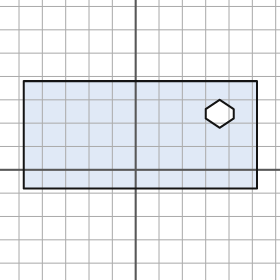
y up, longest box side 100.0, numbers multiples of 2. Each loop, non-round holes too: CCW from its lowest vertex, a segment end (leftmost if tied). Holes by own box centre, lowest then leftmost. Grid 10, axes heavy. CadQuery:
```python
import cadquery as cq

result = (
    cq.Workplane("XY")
    .moveTo(-48.0, -8.0)
    .lineTo(52.0, -8.0)
    .lineTo(52.0, 38.0)
    .lineTo(-48.0, 38.0)
    .close()
    .moveTo(36.0, 18.0)
    .lineTo(42.0, 22.0)
    .lineTo(42.0, 26.0)
    .lineTo(36.0, 30.0)
    .lineTo(30.0, 26.0)
    .lineTo(30.0, 22.0)
    .close()
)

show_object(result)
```